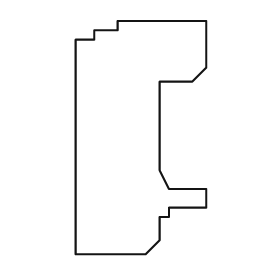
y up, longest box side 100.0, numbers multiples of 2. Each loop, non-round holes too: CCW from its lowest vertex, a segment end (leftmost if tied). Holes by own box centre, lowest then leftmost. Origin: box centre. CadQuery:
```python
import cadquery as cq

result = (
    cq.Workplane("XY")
    .moveTo(-28.0, -50.0)
    .lineTo(2.0, -50.0)
    .lineTo(8.0, -44.0)
    .lineTo(8.0, -34.0)
    .lineTo(12.0, -34.0)
    .lineTo(12.0, -30.0)
    .lineTo(28.0, -30.0)
    .lineTo(28.0, -22.0)
    .lineTo(12.0, -22.0)
    .lineTo(8.0, -14.0)
    .lineTo(8.0, 24.0)
    .lineTo(22.0, 24.0)
    .lineTo(28.0, 30.0)
    .lineTo(28.0, 50.0)
    .lineTo(-10.0, 50.0)
    .lineTo(-10.0, 46.0)
    .lineTo(-20.0, 46.0)
    .lineTo(-20.0, 42.0)
    .lineTo(-28.0, 42.0)
    .close()
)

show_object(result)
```